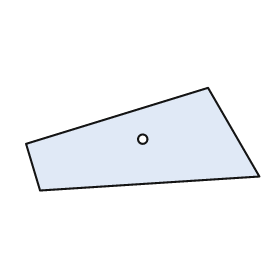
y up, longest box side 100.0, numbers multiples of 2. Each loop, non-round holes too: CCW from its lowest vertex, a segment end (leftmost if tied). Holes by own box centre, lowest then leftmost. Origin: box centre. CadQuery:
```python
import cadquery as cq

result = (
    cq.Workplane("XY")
    .moveTo(-44.0, -22.0)
    .lineTo(50.0, -16.0)
    .lineTo(28.0, 22.0)
    .lineTo(-50.0, -2.0)
    .close()
    .moveTo(0.0, 0.0)
    .circle(2.0)
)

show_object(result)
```